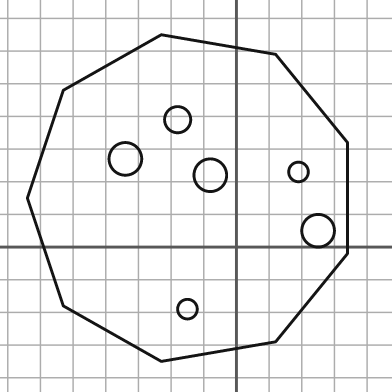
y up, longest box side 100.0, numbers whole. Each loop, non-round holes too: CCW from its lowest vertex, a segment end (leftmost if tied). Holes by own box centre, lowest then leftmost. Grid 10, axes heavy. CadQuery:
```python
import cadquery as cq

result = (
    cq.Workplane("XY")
    .moveTo(-23.0, -35.0)
    .lineTo(12.0, -29.0)
    .lineTo(34.0, -2.0)
    .lineTo(34.0, 32.0)
    .lineTo(12.0, 59.0)
    .lineTo(-23.0, 65.0)
    .lineTo(-53.0, 48.0)
    .lineTo(-64.0, 15.0)
    .lineTo(-53.0, -18.0)
    .close()
    .moveTo(-15.0, -19.0)
    .circle(3.0)
    .moveTo(25.0, 5.0)
    .circle(5.0)
    .moveTo(-8.0, 22.0)
    .circle(5.0)
    .moveTo(19.0, 23.0)
    .circle(3.0)
    .moveTo(-34.0, 27.0)
    .circle(5.0)
    .moveTo(-18.0, 39.0)
    .circle(4.0)
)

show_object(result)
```